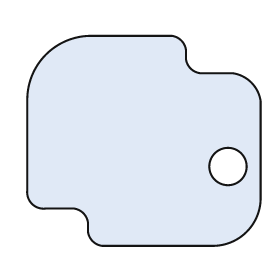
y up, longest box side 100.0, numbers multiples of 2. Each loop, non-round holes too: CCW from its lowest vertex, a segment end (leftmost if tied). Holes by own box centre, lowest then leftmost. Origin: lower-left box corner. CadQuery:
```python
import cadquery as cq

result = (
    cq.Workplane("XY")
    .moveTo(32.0, 0.0)
    .lineTo(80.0, 0.0)
    .threePointArc((94.0, 6.0), (100.0, 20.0))
    .lineTo(100.0, 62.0)
    .threePointArc((96.0, 70.0), (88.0, 74.0))
    .lineTo(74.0, 74.0)
    .threePointArc((70.0, 76.0), (68.0, 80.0))
    .lineTo(68.0, 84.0)
    .threePointArc((66.0, 88.0), (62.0, 90.0))
    .lineTo(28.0, 90.0)
    .threePointArc((8.0, 82.0), (0.0, 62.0))
    .lineTo(0.0, 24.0)
    .threePointArc((2.0, 18.0), (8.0, 16.0))
    .lineTo(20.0, 16.0)
    .threePointArc((24.0, 14.0), (26.0, 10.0))
    .lineTo(26.0, 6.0)
    .threePointArc((28.0, 2.0), (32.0, 0.0))
    .close()
    .moveTo(86.0, 34.0)
    .circle(8.0)
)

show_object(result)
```